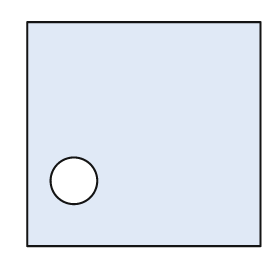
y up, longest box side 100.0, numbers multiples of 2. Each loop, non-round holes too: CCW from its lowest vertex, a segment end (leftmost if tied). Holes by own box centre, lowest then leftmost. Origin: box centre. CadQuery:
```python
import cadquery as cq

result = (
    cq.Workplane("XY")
    .moveTo(-50.0, -48.0)
    .lineTo(50.0, -48.0)
    .lineTo(50.0, 48.0)
    .lineTo(-50.0, 48.0)
    .close()
    .moveTo(-30.0, -20.0)
    .circle(10.0)
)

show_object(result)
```